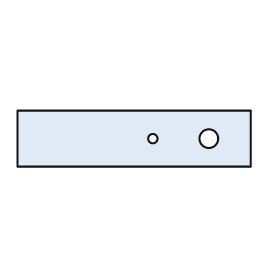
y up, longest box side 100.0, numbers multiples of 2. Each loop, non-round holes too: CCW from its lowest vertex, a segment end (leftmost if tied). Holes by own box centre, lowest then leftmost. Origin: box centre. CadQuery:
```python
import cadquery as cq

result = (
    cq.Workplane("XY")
    .moveTo(-50.0, -12.0)
    .lineTo(50.0, -12.0)
    .lineTo(50.0, 12.0)
    .lineTo(-50.0, 12.0)
    .close()
    .moveTo(8.0, 0.0)
    .circle(2.0)
    .moveTo(32.0, 0.0)
    .circle(4.0)
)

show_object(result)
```